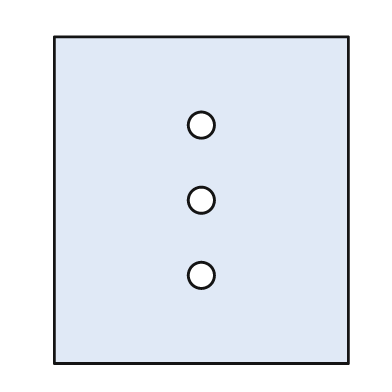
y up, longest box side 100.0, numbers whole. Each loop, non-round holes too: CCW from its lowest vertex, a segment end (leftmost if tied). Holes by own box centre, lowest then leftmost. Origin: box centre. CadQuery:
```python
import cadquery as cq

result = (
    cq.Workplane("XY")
    .moveTo(-45.0, -50.0)
    .lineTo(45.0, -50.0)
    .lineTo(45.0, 50.0)
    .lineTo(-45.0, 50.0)
    .close()
    .moveTo(0.0, -23.0)
    .circle(4.0)
    .moveTo(0.0, 0.0)
    .circle(4.0)
    .moveTo(0.0, 23.0)
    .circle(4.0)
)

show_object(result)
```